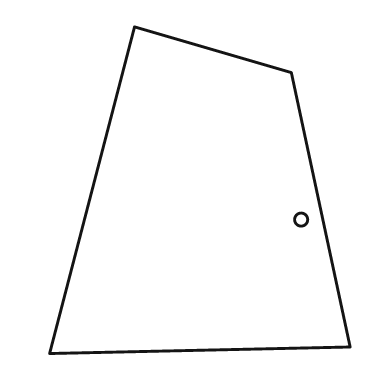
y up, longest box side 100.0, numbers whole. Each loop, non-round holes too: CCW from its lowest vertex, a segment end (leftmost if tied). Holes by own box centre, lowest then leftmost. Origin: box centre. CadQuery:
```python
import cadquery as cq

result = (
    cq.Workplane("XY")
    .moveTo(-46.0, -50.0)
    .lineTo(46.0, -48.0)
    .lineTo(28.0, 36.0)
    .lineTo(-20.0, 50.0)
    .close()
    .moveTo(31.0, -9.0)
    .circle(2.0)
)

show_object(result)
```